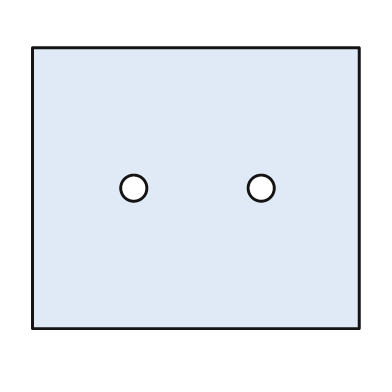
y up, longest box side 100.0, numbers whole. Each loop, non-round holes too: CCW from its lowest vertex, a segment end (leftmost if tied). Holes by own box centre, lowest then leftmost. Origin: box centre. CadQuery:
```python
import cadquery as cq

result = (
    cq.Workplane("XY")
    .moveTo(-50.0, -43.0)
    .lineTo(50.0, -43.0)
    .lineTo(50.0, 43.0)
    .lineTo(-50.0, 43.0)
    .close()
    .moveTo(-19.0, 0.0)
    .circle(4.0)
    .moveTo(20.0, 0.0)
    .circle(4.0)
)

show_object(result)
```